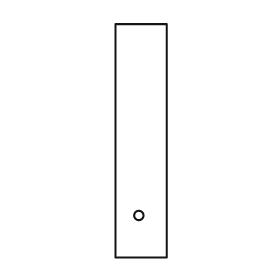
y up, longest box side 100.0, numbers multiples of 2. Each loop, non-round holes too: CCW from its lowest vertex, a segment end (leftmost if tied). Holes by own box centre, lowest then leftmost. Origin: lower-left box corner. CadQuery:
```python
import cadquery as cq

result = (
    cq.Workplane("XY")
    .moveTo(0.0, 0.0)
    .lineTo(22.0, 0.0)
    .lineTo(22.0, 100.0)
    .lineTo(0.0, 100.0)
    .close()
    .moveTo(10.0, 18.0)
    .circle(2.0)
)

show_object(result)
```